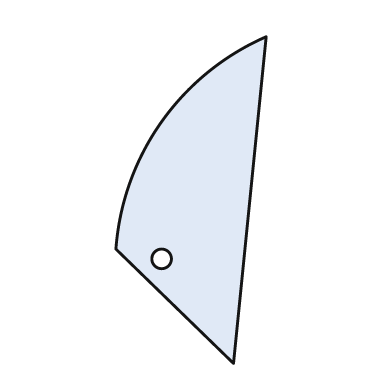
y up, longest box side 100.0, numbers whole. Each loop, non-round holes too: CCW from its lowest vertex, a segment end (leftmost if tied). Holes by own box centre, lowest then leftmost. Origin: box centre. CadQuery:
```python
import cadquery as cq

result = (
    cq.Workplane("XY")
    .moveTo(13.0, -50.0)
    .lineTo(23.0, 50.0)
    .threePointArc((-9.0, 24.0), (-23.0, -15.0))
    .close()
    .moveTo(-9.0, -18.0)
    .circle(3.0)
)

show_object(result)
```